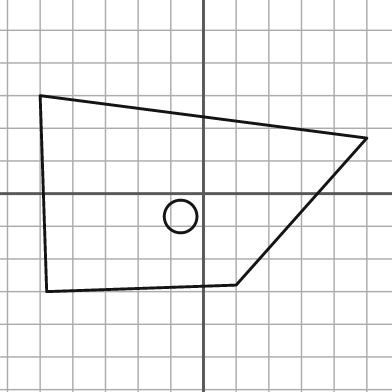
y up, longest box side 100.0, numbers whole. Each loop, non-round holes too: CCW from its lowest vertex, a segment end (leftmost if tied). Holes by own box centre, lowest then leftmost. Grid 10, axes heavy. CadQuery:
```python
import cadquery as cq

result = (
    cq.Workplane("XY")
    .moveTo(-48.0, -30.0)
    .lineTo(10.0, -28.0)
    .lineTo(50.0, 17.0)
    .lineTo(-50.0, 30.0)
    .close()
    .moveTo(-7.0, -7.0)
    .circle(5.0)
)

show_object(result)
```